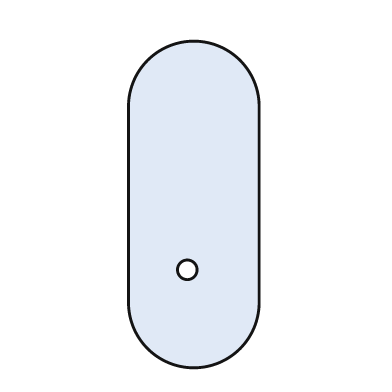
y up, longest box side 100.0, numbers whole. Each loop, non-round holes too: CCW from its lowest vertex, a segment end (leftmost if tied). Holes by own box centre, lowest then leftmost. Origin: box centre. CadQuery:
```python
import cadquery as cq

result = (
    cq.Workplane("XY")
    .moveTo(-20.0, -30.0)
    .threePointArc((0.0, -50.0), (20.0, -30.0))
    .lineTo(20.0, 30.0)
    .threePointArc((0.0, 50.0), (-20.0, 30.0))
    .close()
    .moveTo(-2.0, -20.0)
    .circle(3.0)
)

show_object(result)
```